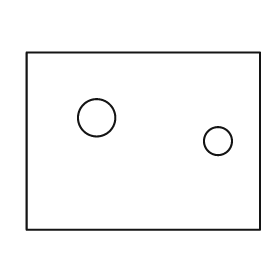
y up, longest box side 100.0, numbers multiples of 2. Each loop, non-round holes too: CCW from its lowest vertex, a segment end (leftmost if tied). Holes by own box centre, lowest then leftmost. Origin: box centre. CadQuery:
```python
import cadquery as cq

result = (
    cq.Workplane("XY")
    .moveTo(-50.0, -38.0)
    .lineTo(50.0, -38.0)
    .lineTo(50.0, 38.0)
    .lineTo(-50.0, 38.0)
    .close()
    .moveTo(32.0, 0.0)
    .circle(6.0)
    .moveTo(-20.0, 10.0)
    .circle(8.0)
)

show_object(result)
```